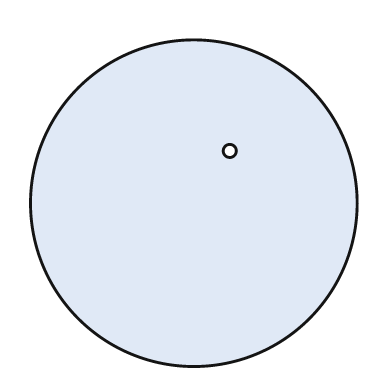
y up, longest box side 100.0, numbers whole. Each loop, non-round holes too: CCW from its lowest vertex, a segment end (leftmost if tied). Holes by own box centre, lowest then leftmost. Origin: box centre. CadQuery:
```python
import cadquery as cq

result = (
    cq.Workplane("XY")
    .moveTo(0.0, 0.0)
    .circle(50.0)
    .moveTo(11.0, 16.0)
    .circle(2.0)
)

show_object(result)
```